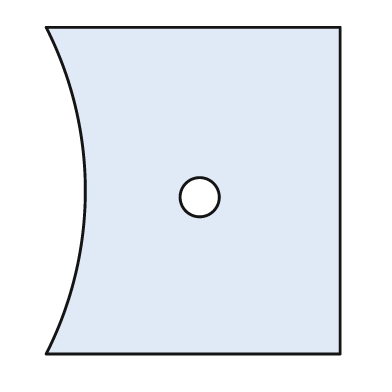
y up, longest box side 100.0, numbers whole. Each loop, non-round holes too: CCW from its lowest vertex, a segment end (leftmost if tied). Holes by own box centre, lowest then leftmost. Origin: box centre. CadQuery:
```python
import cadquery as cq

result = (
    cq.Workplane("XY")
    .moveTo(-45.0, -50.0)
    .lineTo(45.0, -50.0)
    .lineTo(45.0, 50.0)
    .lineTo(-45.0, 50.0)
    .threePointArc((-33.0, 0.0), (-45.0, -50.0))
    .close()
    .moveTo(2.0, -2.0)
    .circle(6.0)
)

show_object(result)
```